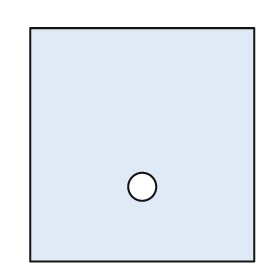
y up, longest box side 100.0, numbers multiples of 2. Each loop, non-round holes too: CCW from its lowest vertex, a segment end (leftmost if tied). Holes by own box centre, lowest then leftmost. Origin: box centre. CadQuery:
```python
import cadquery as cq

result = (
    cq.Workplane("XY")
    .moveTo(-48.0, -50.0)
    .lineTo(48.0, -50.0)
    .lineTo(48.0, 50.0)
    .lineTo(-48.0, 50.0)
    .close()
    .moveTo(0.0, -18.0)
    .circle(6.0)
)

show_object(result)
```